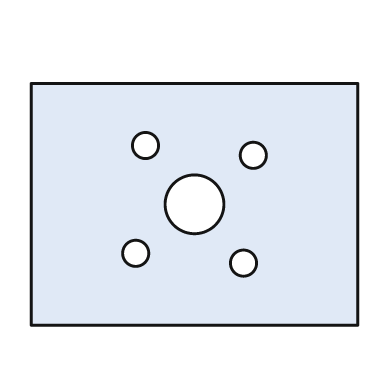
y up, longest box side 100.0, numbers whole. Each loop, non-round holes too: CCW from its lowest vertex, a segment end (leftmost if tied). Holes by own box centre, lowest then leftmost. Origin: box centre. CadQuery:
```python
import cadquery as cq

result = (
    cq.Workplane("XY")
    .moveTo(-50.0, -37.0)
    .lineTo(50.0, -37.0)
    .lineTo(50.0, 37.0)
    .lineTo(-50.0, 37.0)
    .close()
    .moveTo(15.0, -18.0)
    .circle(4.0)
    .moveTo(-18.0, -15.0)
    .circle(4.0)
    .moveTo(0.0, 0.0)
    .circle(9.0)
    .moveTo(18.0, 15.0)
    .circle(4.0)
    .moveTo(-15.0, 18.0)
    .circle(4.0)
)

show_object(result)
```